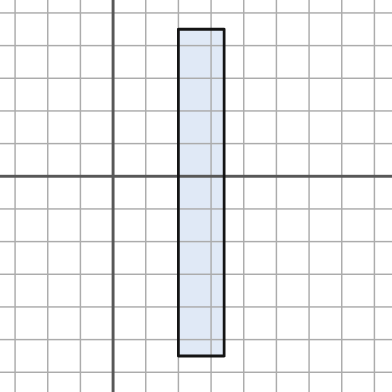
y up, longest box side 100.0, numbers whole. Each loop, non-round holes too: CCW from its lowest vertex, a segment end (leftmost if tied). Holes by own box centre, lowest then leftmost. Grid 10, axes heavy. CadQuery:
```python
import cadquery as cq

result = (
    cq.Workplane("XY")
    .moveTo(20.0, -55.0)
    .lineTo(34.0, -55.0)
    .lineTo(34.0, 45.0)
    .lineTo(20.0, 45.0)
    .close()
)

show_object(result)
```